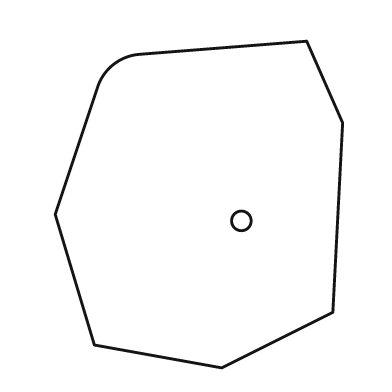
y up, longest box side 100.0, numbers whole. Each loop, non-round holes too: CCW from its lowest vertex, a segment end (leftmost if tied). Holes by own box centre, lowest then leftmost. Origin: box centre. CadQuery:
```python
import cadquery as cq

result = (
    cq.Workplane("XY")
    .moveTo(7.0, -50.0)
    .lineTo(41.0, -33.0)
    .lineTo(44.0, 25.0)
    .lineTo(33.0, 50.0)
    .lineTo(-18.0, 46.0)
    .threePointArc((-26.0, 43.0), (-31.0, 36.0))
    .lineTo(-44.0, -3.0)
    .lineTo(-32.0, -43.0)
    .close()
    .moveTo(13.0, -5.0)
    .circle(3.0)
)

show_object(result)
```